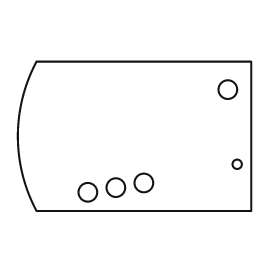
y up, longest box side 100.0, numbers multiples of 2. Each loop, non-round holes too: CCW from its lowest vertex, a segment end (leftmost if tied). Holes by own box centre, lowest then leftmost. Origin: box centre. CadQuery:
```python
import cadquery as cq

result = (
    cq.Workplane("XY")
    .moveTo(-42.0, -32.0)
    .lineTo(50.0, -32.0)
    .lineTo(50.0, 32.0)
    .lineTo(-42.0, 32.0)
    .threePointArc((-50.0, 0.0), (-42.0, -32.0))
    .close()
    .moveTo(-20.0, -24.0)
    .circle(4.0)
    .moveTo(-8.0, -22.0)
    .circle(4.0)
    .moveTo(4.0, -20.0)
    .circle(4.0)
    .moveTo(44.0, -12.0)
    .circle(2.0)
    .moveTo(40.0, 20.0)
    .circle(4.0)
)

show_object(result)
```